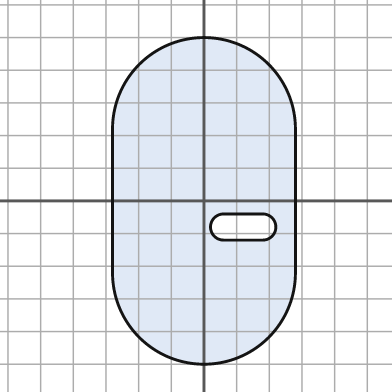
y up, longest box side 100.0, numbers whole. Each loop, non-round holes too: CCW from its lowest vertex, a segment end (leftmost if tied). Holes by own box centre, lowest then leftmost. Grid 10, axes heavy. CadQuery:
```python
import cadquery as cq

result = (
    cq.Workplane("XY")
    .moveTo(-28.0, -22.0)
    .threePointArc((0.0, -50.0), (28.0, -22.0))
    .lineTo(28.0, 22.0)
    .threePointArc((0.0, 50.0), (-28.0, 22.0))
    .close()
    .moveTo(6.0, -12.0)
    .lineTo(18.0, -12.0)
    .threePointArc((22.0, -8.0), (18.0, -4.0))
    .lineTo(6.0, -4.0)
    .threePointArc((2.0, -8.0), (6.0, -12.0))
    .close()
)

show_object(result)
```